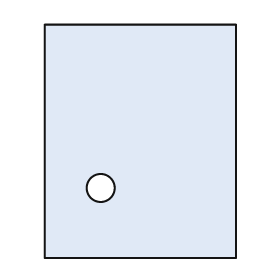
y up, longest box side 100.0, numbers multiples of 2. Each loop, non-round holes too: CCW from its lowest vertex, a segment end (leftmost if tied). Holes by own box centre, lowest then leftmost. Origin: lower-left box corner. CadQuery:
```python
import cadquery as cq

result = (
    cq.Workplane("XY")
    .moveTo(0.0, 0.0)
    .lineTo(82.0, 0.0)
    .lineTo(82.0, 100.0)
    .lineTo(0.0, 100.0)
    .close()
    .moveTo(24.0, 30.0)
    .circle(6.0)
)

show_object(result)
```